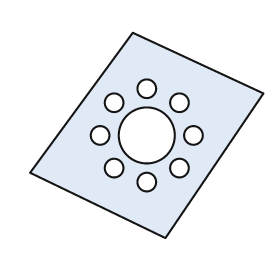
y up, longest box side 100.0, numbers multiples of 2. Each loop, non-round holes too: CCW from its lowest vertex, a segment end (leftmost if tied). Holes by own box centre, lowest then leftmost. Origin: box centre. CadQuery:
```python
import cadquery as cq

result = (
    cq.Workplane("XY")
    .moveTo(8.0, -44.0)
    .lineTo(50.0, 18.0)
    .lineTo(-6.0, 44.0)
    .lineTo(-50.0, -16.0)
    .close()
    .moveTo(0.0, -20.0)
    .circle(4.0)
    .moveTo(-14.0, -14.0)
    .circle(4.0)
    .moveTo(14.0, -14.0)
    .circle(4.0)
    .moveTo(-20.0, 0.0)
    .circle(4.0)
    .moveTo(0.0, 0.0)
    .circle(12.0)
    .moveTo(20.0, 0.0)
    .circle(4.0)
    .moveTo(-14.0, 14.0)
    .circle(4.0)
    .moveTo(14.0, 14.0)
    .circle(4.0)
    .moveTo(0.0, 20.0)
    .circle(4.0)
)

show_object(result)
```